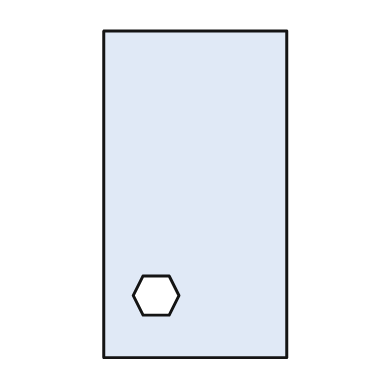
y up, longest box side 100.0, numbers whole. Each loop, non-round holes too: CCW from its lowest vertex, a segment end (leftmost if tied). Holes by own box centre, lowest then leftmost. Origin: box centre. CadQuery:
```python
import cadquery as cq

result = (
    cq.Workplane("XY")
    .moveTo(-28.0, -50.0)
    .lineTo(28.0, -50.0)
    .lineTo(28.0, 50.0)
    .lineTo(-28.0, 50.0)
    .close()
    .moveTo(-16.0, -37.0)
    .lineTo(-8.0, -37.0)
    .lineTo(-5.0, -31.0)
    .lineTo(-8.0, -25.0)
    .lineTo(-16.0, -25.0)
    .lineTo(-19.0, -31.0)
    .close()
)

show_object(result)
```